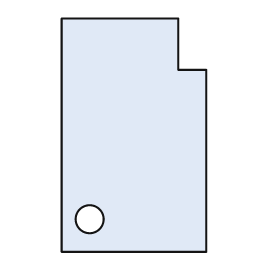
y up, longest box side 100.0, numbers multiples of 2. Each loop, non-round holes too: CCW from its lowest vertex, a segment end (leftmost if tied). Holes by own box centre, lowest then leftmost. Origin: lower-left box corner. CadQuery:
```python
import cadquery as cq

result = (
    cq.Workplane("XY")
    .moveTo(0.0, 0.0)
    .lineTo(62.0, 0.0)
    .lineTo(62.0, 78.0)
    .lineTo(50.0, 78.0)
    .lineTo(50.0, 100.0)
    .lineTo(0.0, 100.0)
    .close()
    .moveTo(12.0, 14.0)
    .circle(6.0)
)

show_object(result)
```